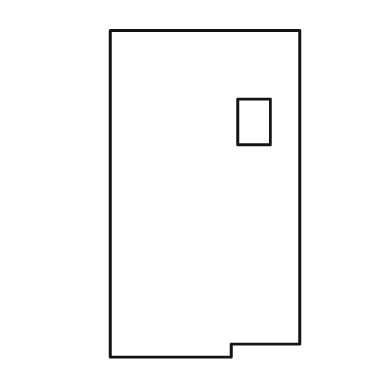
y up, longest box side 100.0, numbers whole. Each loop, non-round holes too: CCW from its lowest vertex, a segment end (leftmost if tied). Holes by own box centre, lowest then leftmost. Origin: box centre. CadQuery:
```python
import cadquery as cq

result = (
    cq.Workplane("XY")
    .moveTo(-29.0, -50.0)
    .lineTo(8.0, -50.0)
    .lineTo(8.0, -46.0)
    .lineTo(29.0, -46.0)
    .lineTo(29.0, 50.0)
    .lineTo(-29.0, 50.0)
    .close()
    .moveTo(10.0, 15.0)
    .lineTo(20.0, 15.0)
    .lineTo(20.0, 29.0)
    .lineTo(10.0, 29.0)
    .close()
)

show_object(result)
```